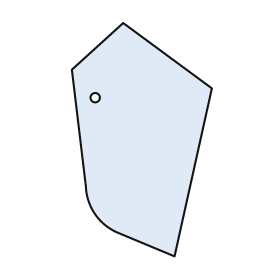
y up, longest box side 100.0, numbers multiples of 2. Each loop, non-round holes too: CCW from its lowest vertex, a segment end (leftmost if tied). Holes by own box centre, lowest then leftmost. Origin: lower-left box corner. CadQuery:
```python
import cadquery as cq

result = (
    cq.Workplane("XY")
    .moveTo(44.0, 0.0)
    .lineTo(60.0, 72.0)
    .lineTo(22.0, 100.0)
    .lineTo(0.0, 80.0)
    .lineTo(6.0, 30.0)
    .threePointArc((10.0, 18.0), (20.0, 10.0))
    .close()
    .moveTo(10.0, 68.0)
    .circle(2.0)
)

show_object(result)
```